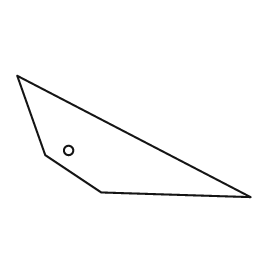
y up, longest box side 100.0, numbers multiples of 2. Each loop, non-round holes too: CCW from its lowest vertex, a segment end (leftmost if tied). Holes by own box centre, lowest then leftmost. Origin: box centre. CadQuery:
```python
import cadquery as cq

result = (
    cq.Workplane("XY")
    .moveTo(50.0, -26.0)
    .lineTo(-50.0, 26.0)
    .lineTo(-38.0, -8.0)
    .lineTo(-14.0, -24.0)
    .close()
    .moveTo(-28.0, -6.0)
    .circle(2.0)
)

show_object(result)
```